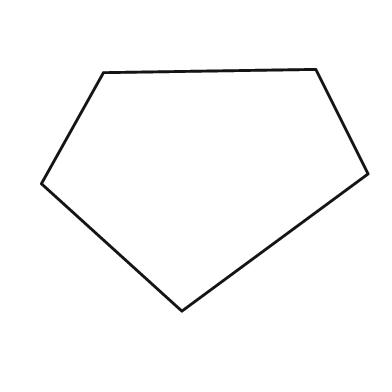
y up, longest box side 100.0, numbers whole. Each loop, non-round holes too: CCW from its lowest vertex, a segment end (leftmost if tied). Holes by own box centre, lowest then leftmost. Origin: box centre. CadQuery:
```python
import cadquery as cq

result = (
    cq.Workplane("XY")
    .moveTo(-7.0, -37.0)
    .lineTo(50.0, 5.0)
    .lineTo(34.0, 37.0)
    .lineTo(-31.0, 36.0)
    .lineTo(-50.0, 2.0)
    .close()
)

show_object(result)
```